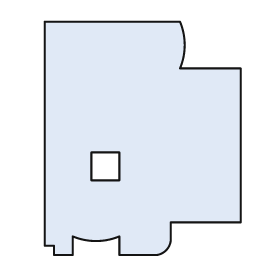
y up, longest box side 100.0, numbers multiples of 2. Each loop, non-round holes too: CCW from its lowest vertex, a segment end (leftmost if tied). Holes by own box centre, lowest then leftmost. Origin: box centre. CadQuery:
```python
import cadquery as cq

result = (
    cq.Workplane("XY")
    .moveTo(-38.0, -50.0)
    .lineTo(-30.0, -50.0)
    .lineTo(-30.0, -42.0)
    .threePointArc((-20.0, -44.0), (-10.0, -42.0))
    .lineTo(-10.0, -50.0)
    .lineTo(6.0, -50.0)
    .threePointArc((10.0, -48.0), (12.0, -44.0))
    .lineTo(12.0, -36.0)
    .lineTo(42.0, -36.0)
    .lineTo(42.0, 30.0)
    .lineTo(16.0, 30.0)
    .threePointArc((18.0, 40.0), (16.0, 50.0))
    .lineTo(-42.0, 50.0)
    .lineTo(-42.0, -46.0)
    .lineTo(-38.0, -46.0)
    .close()
    .moveTo(-22.0, -18.0)
    .lineTo(-10.0, -18.0)
    .lineTo(-10.0, -6.0)
    .lineTo(-22.0, -6.0)
    .close()
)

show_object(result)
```